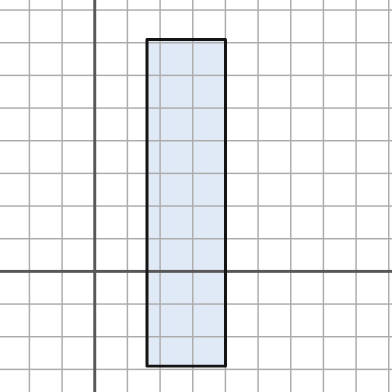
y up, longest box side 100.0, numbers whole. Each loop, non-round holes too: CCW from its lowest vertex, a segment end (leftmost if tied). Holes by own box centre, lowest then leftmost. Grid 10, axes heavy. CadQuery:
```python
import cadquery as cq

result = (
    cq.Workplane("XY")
    .moveTo(16.0, -29.0)
    .lineTo(40.0, -29.0)
    .lineTo(40.0, 71.0)
    .lineTo(16.0, 71.0)
    .close()
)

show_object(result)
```